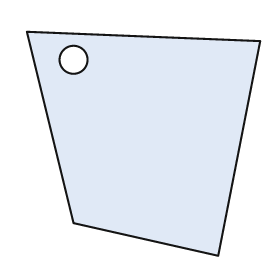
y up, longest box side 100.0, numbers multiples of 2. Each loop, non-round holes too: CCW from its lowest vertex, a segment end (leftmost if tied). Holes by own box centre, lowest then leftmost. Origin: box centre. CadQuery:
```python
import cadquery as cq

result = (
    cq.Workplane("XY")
    .moveTo(32.0, -48.0)
    .lineTo(50.0, 44.0)
    .lineTo(-50.0, 48.0)
    .lineTo(-30.0, -34.0)
    .close()
    .moveTo(-30.0, 36.0)
    .circle(6.0)
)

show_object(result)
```